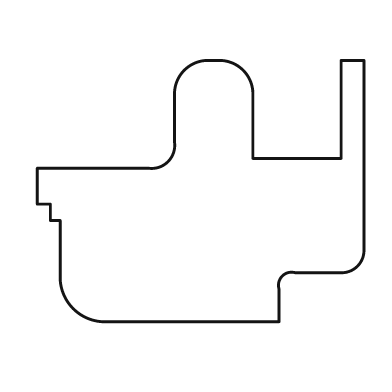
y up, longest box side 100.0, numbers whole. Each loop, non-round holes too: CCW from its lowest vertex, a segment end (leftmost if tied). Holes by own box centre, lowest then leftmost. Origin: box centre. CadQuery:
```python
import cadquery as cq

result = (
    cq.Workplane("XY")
    .moveTo(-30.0, -40.0)
    .lineTo(24.0, -40.0)
    .lineTo(24.0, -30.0)
    .threePointArc((25.0, -26.0), (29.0, -25.0))
    .lineTo(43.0, -25.0)
    .threePointArc((48.0, -23.0), (50.0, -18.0))
    .lineTo(50.0, 40.0)
    .lineTo(43.0, 40.0)
    .lineTo(43.0, 10.0)
    .lineTo(16.0, 10.0)
    .lineTo(16.0, 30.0)
    .threePointArc((13.0, 37.0), (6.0, 40.0))
    .lineTo(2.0, 40.0)
    .threePointArc((-5.0, 37.0), (-8.0, 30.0))
    .lineTo(-8.0, 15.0)
    .threePointArc((-10.0, 9.0), (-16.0, 7.0))
    .lineTo(-50.0, 7.0)
    .lineTo(-50.0, -4.0)
    .lineTo(-46.0, -4.0)
    .lineTo(-46.0, -9.0)
    .lineTo(-43.0, -9.0)
    .lineTo(-43.0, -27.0)
    .threePointArc((-39.0, -36.0), (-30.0, -40.0))
    .close()
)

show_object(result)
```